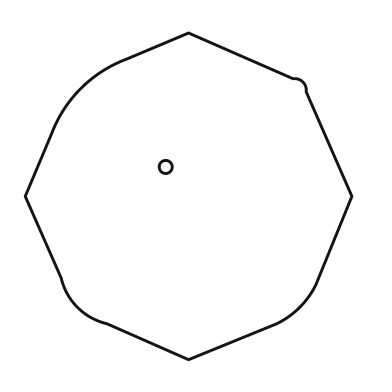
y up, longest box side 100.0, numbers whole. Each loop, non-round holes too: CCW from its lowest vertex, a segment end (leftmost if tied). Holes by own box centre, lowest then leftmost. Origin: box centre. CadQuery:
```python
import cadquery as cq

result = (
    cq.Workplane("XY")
    .moveTo(0.0, -50.0)
    .lineTo(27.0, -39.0)
    .threePointArc((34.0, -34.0), (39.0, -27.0))
    .lineTo(50.0, 0.0)
    .lineTo(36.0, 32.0)
    .threePointArc((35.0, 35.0), (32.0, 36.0))
    .lineTo(0.0, 50.0)
    .lineTo(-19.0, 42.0)
    .threePointArc((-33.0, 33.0), (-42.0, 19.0))
    .lineTo(-50.0, 0.0)
    .lineTo(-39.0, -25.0)
    .threePointArc((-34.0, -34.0), (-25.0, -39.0))
    .close()
    .moveTo(-7.0, 9.0)
    .circle(2.0)
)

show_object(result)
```